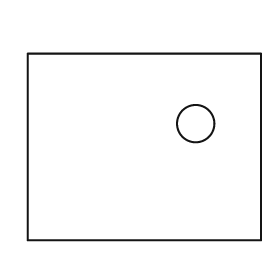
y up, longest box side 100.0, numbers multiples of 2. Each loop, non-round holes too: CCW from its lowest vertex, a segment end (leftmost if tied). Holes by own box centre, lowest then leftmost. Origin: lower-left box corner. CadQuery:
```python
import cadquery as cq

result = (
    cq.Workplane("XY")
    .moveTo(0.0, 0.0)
    .lineTo(100.0, 0.0)
    .lineTo(100.0, 80.0)
    .lineTo(0.0, 80.0)
    .close()
    .moveTo(72.0, 50.0)
    .circle(8.0)
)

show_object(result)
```